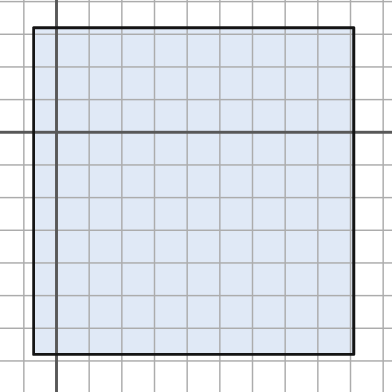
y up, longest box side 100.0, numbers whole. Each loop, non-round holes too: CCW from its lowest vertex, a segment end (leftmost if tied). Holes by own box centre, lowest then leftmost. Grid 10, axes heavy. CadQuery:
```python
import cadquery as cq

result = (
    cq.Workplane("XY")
    .moveTo(-7.0, -68.0)
    .lineTo(91.0, -68.0)
    .lineTo(91.0, 32.0)
    .lineTo(-7.0, 32.0)
    .close()
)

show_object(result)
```